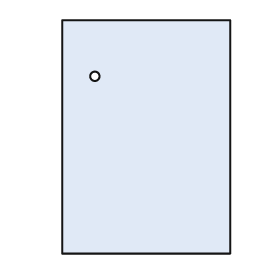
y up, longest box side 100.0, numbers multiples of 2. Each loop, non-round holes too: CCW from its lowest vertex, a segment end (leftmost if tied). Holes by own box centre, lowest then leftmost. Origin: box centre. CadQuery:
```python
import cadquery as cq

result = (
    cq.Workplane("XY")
    .moveTo(-36.0, -50.0)
    .lineTo(36.0, -50.0)
    .lineTo(36.0, 50.0)
    .lineTo(-36.0, 50.0)
    .close()
    .moveTo(-22.0, 26.0)
    .circle(2.0)
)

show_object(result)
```